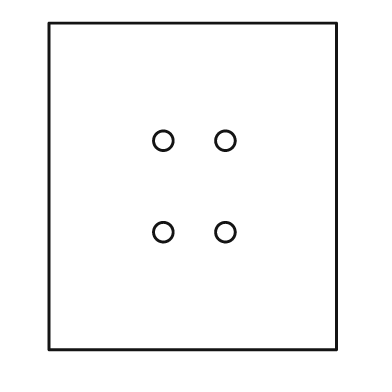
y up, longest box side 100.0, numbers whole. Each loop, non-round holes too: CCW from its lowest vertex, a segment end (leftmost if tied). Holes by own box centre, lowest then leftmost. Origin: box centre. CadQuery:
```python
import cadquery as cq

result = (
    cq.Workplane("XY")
    .moveTo(-44.0, -50.0)
    .lineTo(44.0, -50.0)
    .lineTo(44.0, 50.0)
    .lineTo(-44.0, 50.0)
    .close()
    .moveTo(-9.0, -14.0)
    .circle(3.0)
    .moveTo(10.0, -14.0)
    .circle(3.0)
    .moveTo(-9.0, 14.0)
    .circle(3.0)
    .moveTo(10.0, 14.0)
    .circle(3.0)
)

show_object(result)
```